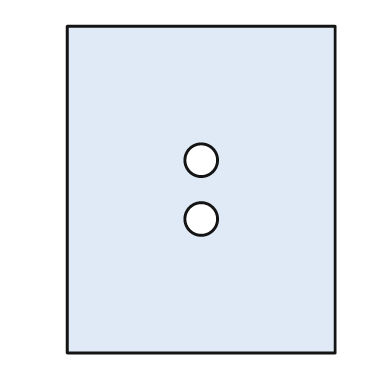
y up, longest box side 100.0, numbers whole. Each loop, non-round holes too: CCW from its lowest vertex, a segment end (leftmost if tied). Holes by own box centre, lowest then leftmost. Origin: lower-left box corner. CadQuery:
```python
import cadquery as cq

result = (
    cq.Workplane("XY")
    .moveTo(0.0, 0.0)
    .lineTo(82.0, 0.0)
    .lineTo(82.0, 100.0)
    .lineTo(0.0, 100.0)
    .close()
    .moveTo(41.0, 41.0)
    .circle(5.0)
    .moveTo(41.0, 59.0)
    .circle(5.0)
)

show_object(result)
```